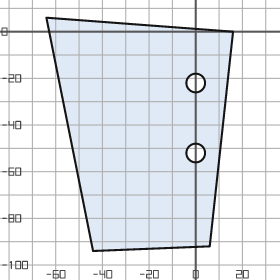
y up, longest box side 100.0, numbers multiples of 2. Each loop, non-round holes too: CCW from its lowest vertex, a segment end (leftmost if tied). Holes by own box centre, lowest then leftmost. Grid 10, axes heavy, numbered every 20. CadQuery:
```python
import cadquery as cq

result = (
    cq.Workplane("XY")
    .moveTo(-44.0, -94.0)
    .lineTo(6.0, -92.0)
    .lineTo(16.0, 0.0)
    .lineTo(-64.0, 6.0)
    .close()
    .moveTo(0.0, -52.0)
    .circle(4.0)
    .moveTo(0.0, -22.0)
    .circle(4.0)
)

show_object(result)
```